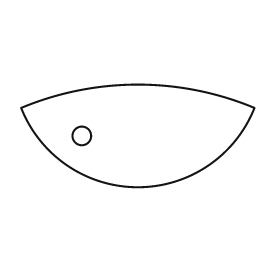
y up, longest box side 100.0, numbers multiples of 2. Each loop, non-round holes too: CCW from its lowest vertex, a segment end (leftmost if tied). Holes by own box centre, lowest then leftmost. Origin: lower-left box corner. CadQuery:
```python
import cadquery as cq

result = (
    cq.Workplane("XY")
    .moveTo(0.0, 34.0)
    .threePointArc((50.0, 0.0), (100.0, 34.0))
    .threePointArc((50.0, 44.0), (0.0, 34.0))
    .close()
    .moveTo(26.0, 22.0)
    .circle(4.0)
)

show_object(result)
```